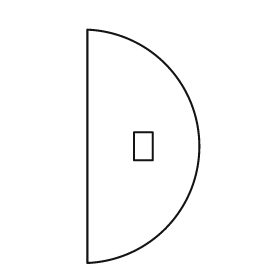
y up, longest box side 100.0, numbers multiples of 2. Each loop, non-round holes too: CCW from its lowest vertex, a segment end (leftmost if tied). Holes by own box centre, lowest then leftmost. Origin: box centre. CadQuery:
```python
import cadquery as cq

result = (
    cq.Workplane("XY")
    .moveTo(-24.0, -50.0)
    .threePointArc((24.0, 0.0), (-24.0, 50.0))
    .close()
    .moveTo(-4.0, -6.0)
    .lineTo(4.0, -6.0)
    .lineTo(4.0, 6.0)
    .lineTo(-4.0, 6.0)
    .close()
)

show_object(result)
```